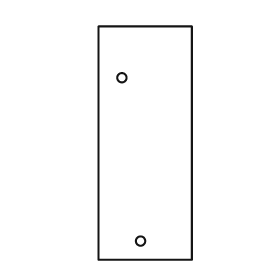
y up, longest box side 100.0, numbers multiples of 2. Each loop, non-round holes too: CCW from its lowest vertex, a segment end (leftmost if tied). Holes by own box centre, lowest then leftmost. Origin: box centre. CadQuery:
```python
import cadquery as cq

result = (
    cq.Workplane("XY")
    .moveTo(-20.0, -50.0)
    .lineTo(20.0, -50.0)
    .lineTo(20.0, 50.0)
    .lineTo(-20.0, 50.0)
    .close()
    .moveTo(-2.0, -42.0)
    .circle(2.0)
    .moveTo(-10.0, 28.0)
    .circle(2.0)
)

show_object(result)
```